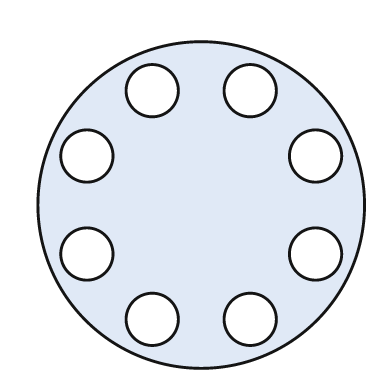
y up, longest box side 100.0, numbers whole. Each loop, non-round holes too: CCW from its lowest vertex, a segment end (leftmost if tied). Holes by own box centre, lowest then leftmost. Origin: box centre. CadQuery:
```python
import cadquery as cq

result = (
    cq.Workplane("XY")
    .moveTo(0.0, 0.0)
    .circle(50.0)
    .moveTo(-15.0, -35.0)
    .circle(8.0)
    .moveTo(15.0, -35.0)
    .circle(8.0)
    .moveTo(-35.0, -15.0)
    .circle(8.0)
    .moveTo(35.0, -15.0)
    .circle(8.0)
    .moveTo(-35.0, 15.0)
    .circle(8.0)
    .moveTo(35.0, 15.0)
    .circle(8.0)
    .moveTo(-15.0, 35.0)
    .circle(8.0)
    .moveTo(15.0, 35.0)
    .circle(8.0)
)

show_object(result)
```